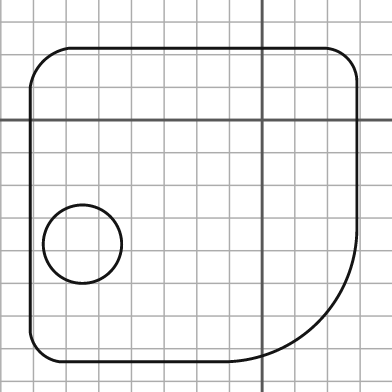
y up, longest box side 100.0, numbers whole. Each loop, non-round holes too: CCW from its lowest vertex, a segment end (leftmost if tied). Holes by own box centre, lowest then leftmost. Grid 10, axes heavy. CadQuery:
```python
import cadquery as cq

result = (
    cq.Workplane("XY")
    .moveTo(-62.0, -74.0)
    .lineTo(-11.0, -74.0)
    .threePointArc((17.0, -62.0), (29.0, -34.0))
    .lineTo(29.0, 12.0)
    .threePointArc((26.0, 19.0), (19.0, 22.0))
    .lineTo(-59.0, 22.0)
    .threePointArc((-67.0, 18.0), (-71.0, 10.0))
    .lineTo(-71.0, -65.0)
    .threePointArc((-68.0, -71.0), (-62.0, -74.0))
    .close()
    .moveTo(-55.0, -38.0)
    .circle(12.0)
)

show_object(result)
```